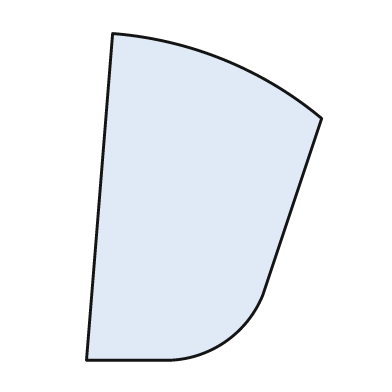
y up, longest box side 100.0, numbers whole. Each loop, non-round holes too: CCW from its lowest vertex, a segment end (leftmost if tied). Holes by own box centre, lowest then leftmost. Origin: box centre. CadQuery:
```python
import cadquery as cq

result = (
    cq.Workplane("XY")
    .moveTo(-36.0, -50.0)
    .lineTo(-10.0, -50.0)
    .threePointArc((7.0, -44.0), (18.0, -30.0))
    .lineTo(36.0, 24.0)
    .threePointArc((6.0, 42.0), (-28.0, 50.0))
    .close()
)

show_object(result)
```